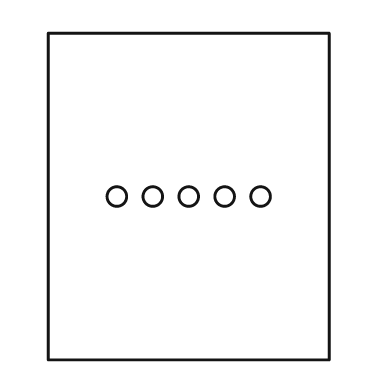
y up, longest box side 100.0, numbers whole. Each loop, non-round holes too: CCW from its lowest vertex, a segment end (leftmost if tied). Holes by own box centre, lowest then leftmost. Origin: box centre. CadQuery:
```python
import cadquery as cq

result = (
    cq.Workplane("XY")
    .moveTo(-43.0, -50.0)
    .lineTo(43.0, -50.0)
    .lineTo(43.0, 50.0)
    .lineTo(-43.0, 50.0)
    .close()
    .moveTo(-22.0, 0.0)
    .circle(3.0)
    .moveTo(-11.0, 0.0)
    .circle(3.0)
    .moveTo(0.0, 0.0)
    .circle(3.0)
    .moveTo(11.0, 0.0)
    .circle(3.0)
    .moveTo(22.0, 0.0)
    .circle(3.0)
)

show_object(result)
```